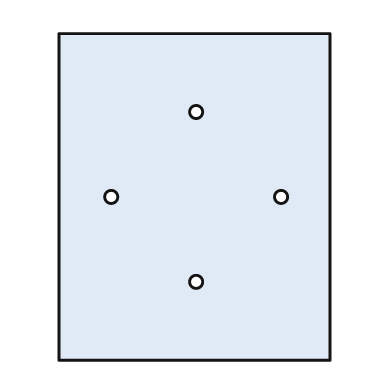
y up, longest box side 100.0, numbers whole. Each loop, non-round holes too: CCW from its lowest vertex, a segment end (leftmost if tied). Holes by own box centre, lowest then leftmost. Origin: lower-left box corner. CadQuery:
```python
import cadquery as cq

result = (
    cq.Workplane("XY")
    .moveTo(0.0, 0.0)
    .lineTo(83.0, 0.0)
    .lineTo(83.0, 100.0)
    .lineTo(0.0, 100.0)
    .close()
    .moveTo(42.0, 24.0)
    .circle(2.0)
    .moveTo(16.0, 50.0)
    .circle(2.0)
    .moveTo(68.0, 50.0)
    .circle(2.0)
    .moveTo(42.0, 76.0)
    .circle(2.0)
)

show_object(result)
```